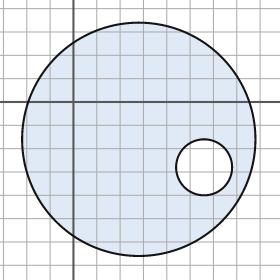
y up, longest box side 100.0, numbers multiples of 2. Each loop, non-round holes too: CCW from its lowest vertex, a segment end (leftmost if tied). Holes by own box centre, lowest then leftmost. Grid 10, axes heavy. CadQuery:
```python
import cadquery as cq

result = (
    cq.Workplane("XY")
    .moveTo(28.0, -16.0)
    .circle(50.0)
    .moveTo(56.0, -28.0)
    .circle(12.0)
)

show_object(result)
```